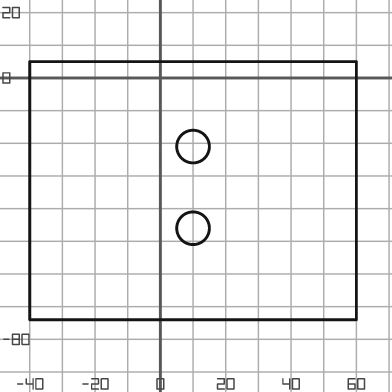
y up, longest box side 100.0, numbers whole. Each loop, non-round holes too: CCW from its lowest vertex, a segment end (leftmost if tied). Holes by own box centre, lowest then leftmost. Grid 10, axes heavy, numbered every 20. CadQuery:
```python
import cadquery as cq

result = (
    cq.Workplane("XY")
    .moveTo(-40.0, -74.0)
    .lineTo(60.0, -74.0)
    .lineTo(60.0, 5.0)
    .lineTo(-40.0, 5.0)
    .close()
    .moveTo(10.0, -46.0)
    .circle(5.0)
    .moveTo(10.0, -21.0)
    .circle(5.0)
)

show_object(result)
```